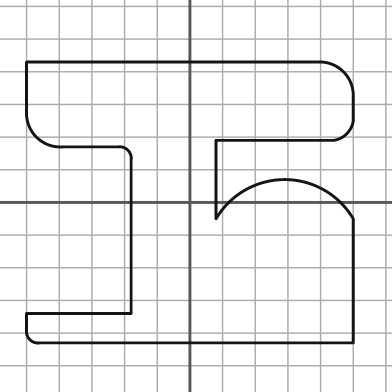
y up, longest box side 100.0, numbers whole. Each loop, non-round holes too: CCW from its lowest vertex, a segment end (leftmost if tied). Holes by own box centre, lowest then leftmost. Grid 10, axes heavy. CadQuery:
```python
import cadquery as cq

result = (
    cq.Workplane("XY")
    .moveTo(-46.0, -43.0)
    .lineTo(50.0, -43.0)
    .lineTo(50.0, -5.0)
    .threePointArc((29.0, 7.0), (8.0, -5.0))
    .lineTo(8.0, 19.0)
    .lineTo(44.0, 19.0)
    .threePointArc((48.0, 21.0), (50.0, 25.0))
    .lineTo(50.0, 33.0)
    .threePointArc((47.0, 40.0), (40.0, 43.0))
    .lineTo(-50.0, 43.0)
    .lineTo(-50.0, 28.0)
    .threePointArc((-47.0, 20.0), (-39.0, 17.0))
    .lineTo(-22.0, 17.0)
    .threePointArc((-19.0, 16.0), (-18.0, 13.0))
    .lineTo(-18.0, -34.0)
    .lineTo(-50.0, -34.0)
    .lineTo(-50.0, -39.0)
    .threePointArc((-49.0, -42.0), (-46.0, -43.0))
    .close()
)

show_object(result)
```